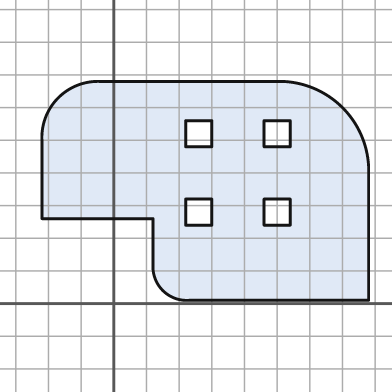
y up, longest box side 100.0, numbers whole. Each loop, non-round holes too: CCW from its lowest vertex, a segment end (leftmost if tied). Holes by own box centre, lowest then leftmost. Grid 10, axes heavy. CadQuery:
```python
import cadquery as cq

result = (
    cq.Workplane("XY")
    .moveTo(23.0, 1.0)
    .lineTo(78.0, 1.0)
    .lineTo(78.0, 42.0)
    .threePointArc((70.0, 60.0), (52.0, 68.0))
    .lineTo(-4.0, 68.0)
    .threePointArc((-17.0, 63.0), (-22.0, 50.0))
    .lineTo(-22.0, 26.0)
    .lineTo(12.0, 26.0)
    .lineTo(12.0, 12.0)
    .threePointArc((15.0, 4.0), (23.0, 1.0))
    .close()
    .moveTo(22.0, 24.0)
    .lineTo(30.0, 24.0)
    .lineTo(30.0, 32.0)
    .lineTo(22.0, 32.0)
    .close()
    .moveTo(46.0, 24.0)
    .lineTo(54.0, 24.0)
    .lineTo(54.0, 32.0)
    .lineTo(46.0, 32.0)
    .close()
    .moveTo(22.0, 48.0)
    .lineTo(30.0, 48.0)
    .lineTo(30.0, 56.0)
    .lineTo(22.0, 56.0)
    .close()
    .moveTo(46.0, 48.0)
    .lineTo(54.0, 48.0)
    .lineTo(54.0, 56.0)
    .lineTo(46.0, 56.0)
    .close()
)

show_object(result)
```